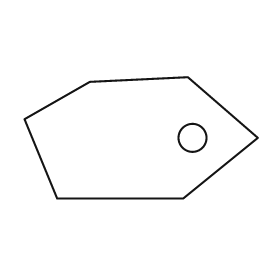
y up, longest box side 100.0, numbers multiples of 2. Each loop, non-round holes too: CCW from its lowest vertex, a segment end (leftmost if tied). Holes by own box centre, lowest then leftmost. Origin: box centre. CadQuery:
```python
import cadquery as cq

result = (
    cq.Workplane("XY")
    .moveTo(-36.0, -26.0)
    .lineTo(18.0, -26.0)
    .lineTo(50.0, 0.0)
    .lineTo(20.0, 26.0)
    .lineTo(-22.0, 24.0)
    .lineTo(-50.0, 8.0)
    .close()
    .moveTo(22.0, 0.0)
    .circle(6.0)
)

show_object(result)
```